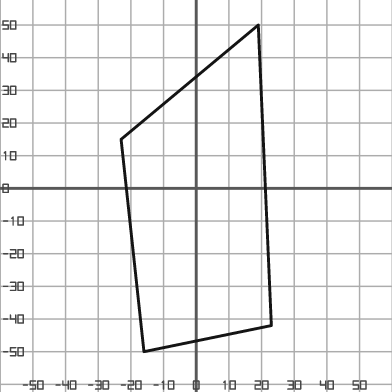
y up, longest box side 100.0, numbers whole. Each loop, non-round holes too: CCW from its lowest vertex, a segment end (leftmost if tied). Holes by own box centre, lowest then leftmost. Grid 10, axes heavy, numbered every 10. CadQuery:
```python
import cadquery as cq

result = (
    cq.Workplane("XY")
    .moveTo(-16.0, -50.0)
    .lineTo(23.0, -42.0)
    .lineTo(19.0, 50.0)
    .lineTo(-23.0, 15.0)
    .close()
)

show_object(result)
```